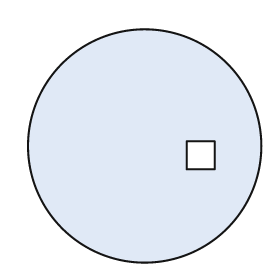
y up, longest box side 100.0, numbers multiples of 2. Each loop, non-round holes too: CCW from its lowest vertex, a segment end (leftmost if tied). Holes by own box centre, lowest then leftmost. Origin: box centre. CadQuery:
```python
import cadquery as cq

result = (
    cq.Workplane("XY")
    .moveTo(0.0, 0.0)
    .circle(50.0)
    .moveTo(18.0, -10.0)
    .lineTo(30.0, -10.0)
    .lineTo(30.0, 2.0)
    .lineTo(18.0, 2.0)
    .close()
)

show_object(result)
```